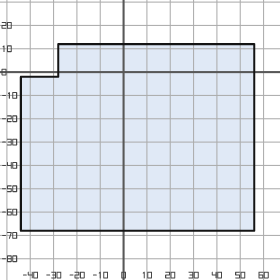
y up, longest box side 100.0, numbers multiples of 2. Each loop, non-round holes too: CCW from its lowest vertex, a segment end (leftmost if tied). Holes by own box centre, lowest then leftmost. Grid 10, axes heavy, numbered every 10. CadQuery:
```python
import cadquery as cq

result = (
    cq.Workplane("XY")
    .moveTo(-44.0, -68.0)
    .lineTo(56.0, -68.0)
    .lineTo(56.0, 12.0)
    .lineTo(-28.0, 12.0)
    .lineTo(-28.0, -2.0)
    .lineTo(-44.0, -2.0)
    .close()
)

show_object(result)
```